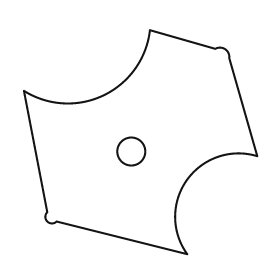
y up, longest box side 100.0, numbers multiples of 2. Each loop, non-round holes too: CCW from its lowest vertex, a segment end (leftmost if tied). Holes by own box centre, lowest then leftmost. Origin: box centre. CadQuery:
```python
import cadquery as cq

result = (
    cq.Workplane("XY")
    .moveTo(20.0, -48.0)
    .threePointArc((20.0, -16.0), (50.0, -6.0))
    .lineTo(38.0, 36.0)
    .threePointArc((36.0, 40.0), (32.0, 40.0))
    .lineTo(4.0, 48.0)
    .threePointArc((-16.0, 20.0), (-50.0, 22.0))
    .lineTo(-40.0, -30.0)
    .threePointArc((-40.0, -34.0), (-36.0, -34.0))
    .close()
    .moveTo(-4.0, -4.0)
    .circle(6.0)
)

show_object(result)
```